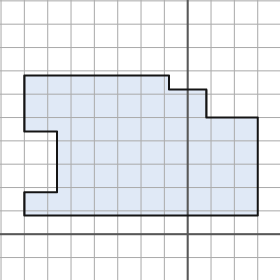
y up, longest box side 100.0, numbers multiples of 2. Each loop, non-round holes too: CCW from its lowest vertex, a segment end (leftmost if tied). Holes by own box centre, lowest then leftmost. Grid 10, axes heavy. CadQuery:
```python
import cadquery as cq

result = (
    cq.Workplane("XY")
    .moveTo(-70.0, 8.0)
    .lineTo(30.0, 8.0)
    .lineTo(30.0, 50.0)
    .lineTo(8.0, 50.0)
    .lineTo(8.0, 62.0)
    .lineTo(-8.0, 62.0)
    .lineTo(-8.0, 68.0)
    .lineTo(-70.0, 68.0)
    .lineTo(-70.0, 44.0)
    .lineTo(-56.0, 44.0)
    .lineTo(-56.0, 18.0)
    .lineTo(-70.0, 18.0)
    .close()
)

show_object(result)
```